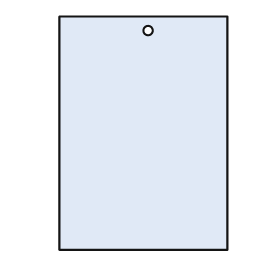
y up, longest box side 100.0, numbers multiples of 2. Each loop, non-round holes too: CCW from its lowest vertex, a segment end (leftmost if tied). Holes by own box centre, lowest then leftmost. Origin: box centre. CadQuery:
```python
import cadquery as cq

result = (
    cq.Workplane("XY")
    .moveTo(-36.0, -50.0)
    .lineTo(36.0, -50.0)
    .lineTo(36.0, 50.0)
    .lineTo(-36.0, 50.0)
    .close()
    .moveTo(2.0, 44.0)
    .circle(2.0)
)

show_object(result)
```